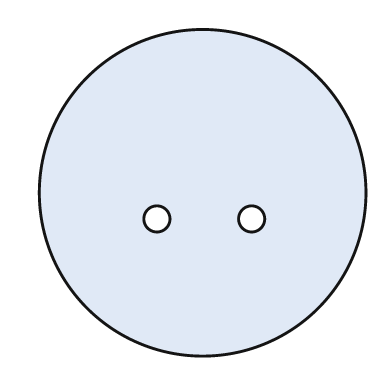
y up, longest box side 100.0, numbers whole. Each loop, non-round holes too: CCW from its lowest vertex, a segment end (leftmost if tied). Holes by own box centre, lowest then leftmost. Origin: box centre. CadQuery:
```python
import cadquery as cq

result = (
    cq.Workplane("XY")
    .moveTo(0.0, 0.0)
    .circle(50.0)
    .moveTo(-14.0, -8.0)
    .circle(4.0)
    .moveTo(15.0, -8.0)
    .circle(4.0)
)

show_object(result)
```